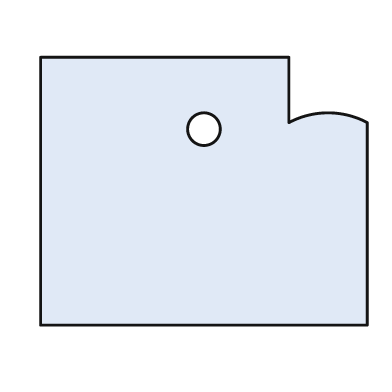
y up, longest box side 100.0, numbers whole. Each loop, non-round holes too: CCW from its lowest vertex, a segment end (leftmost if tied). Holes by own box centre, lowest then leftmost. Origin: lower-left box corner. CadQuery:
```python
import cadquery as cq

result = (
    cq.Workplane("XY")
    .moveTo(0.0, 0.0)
    .lineTo(100.0, 0.0)
    .lineTo(100.0, 62.0)
    .threePointArc((88.0, 65.0), (76.0, 62.0))
    .lineTo(76.0, 82.0)
    .lineTo(0.0, 82.0)
    .close()
    .moveTo(50.0, 60.0)
    .circle(5.0)
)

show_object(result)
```